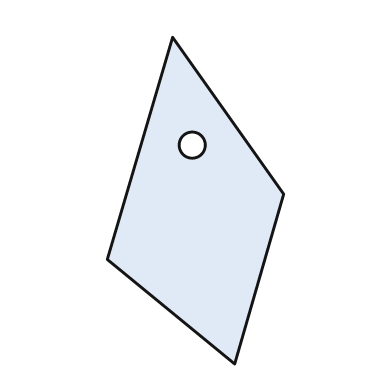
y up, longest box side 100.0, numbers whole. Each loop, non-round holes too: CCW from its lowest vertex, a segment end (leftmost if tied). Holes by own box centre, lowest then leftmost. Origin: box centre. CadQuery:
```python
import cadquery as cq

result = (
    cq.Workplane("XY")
    .moveTo(12.0, -50.0)
    .lineTo(27.0, 2.0)
    .lineTo(-7.0, 50.0)
    .lineTo(-27.0, -18.0)
    .close()
    .moveTo(-1.0, 17.0)
    .circle(4.0)
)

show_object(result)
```